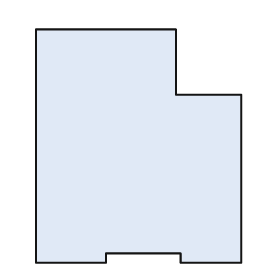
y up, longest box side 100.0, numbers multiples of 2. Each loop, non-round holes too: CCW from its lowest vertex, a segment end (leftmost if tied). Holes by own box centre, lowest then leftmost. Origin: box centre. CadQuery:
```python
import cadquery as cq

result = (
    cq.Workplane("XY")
    .moveTo(-44.0, -50.0)
    .lineTo(-14.0, -50.0)
    .lineTo(-14.0, -46.0)
    .lineTo(18.0, -46.0)
    .lineTo(18.0, -50.0)
    .lineTo(44.0, -50.0)
    .lineTo(44.0, 22.0)
    .lineTo(16.0, 22.0)
    .lineTo(16.0, 50.0)
    .lineTo(-44.0, 50.0)
    .close()
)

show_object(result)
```